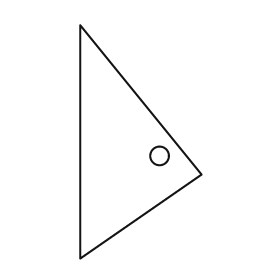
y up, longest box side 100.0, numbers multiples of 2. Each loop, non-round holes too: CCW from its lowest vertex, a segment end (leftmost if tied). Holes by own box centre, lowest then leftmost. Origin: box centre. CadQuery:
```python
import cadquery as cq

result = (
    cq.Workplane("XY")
    .moveTo(-26.0, -50.0)
    .lineTo(26.0, -14.0)
    .lineTo(-26.0, 50.0)
    .close()
    .moveTo(8.0, -6.0)
    .circle(4.0)
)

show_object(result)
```